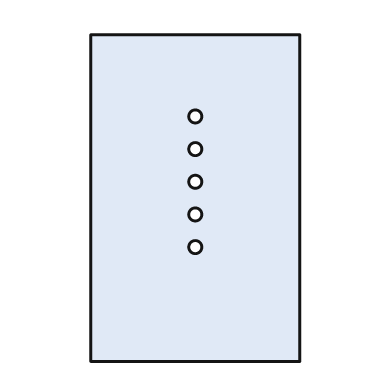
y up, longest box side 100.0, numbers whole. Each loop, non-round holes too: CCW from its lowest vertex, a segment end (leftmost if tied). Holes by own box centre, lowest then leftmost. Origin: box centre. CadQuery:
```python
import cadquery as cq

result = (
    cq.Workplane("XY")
    .moveTo(-32.0, -50.0)
    .lineTo(32.0, -50.0)
    .lineTo(32.0, 50.0)
    .lineTo(-32.0, 50.0)
    .close()
    .moveTo(0.0, -15.0)
    .circle(2.0)
    .moveTo(0.0, -5.0)
    .circle(2.0)
    .moveTo(0.0, 5.0)
    .circle(2.0)
    .moveTo(0.0, 15.0)
    .circle(2.0)
    .moveTo(0.0, 25.0)
    .circle(2.0)
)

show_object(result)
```